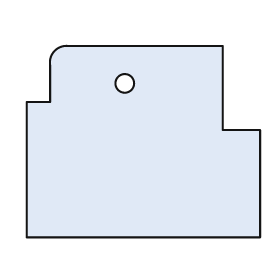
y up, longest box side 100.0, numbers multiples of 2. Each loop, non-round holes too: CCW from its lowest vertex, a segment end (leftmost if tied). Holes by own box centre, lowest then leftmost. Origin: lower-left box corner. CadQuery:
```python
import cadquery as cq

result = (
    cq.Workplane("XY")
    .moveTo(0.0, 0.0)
    .lineTo(100.0, 0.0)
    .lineTo(100.0, 46.0)
    .lineTo(84.0, 46.0)
    .lineTo(84.0, 82.0)
    .lineTo(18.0, 82.0)
    .threePointArc((12.0, 80.0), (10.0, 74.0))
    .lineTo(10.0, 58.0)
    .lineTo(0.0, 58.0)
    .close()
    .moveTo(42.0, 66.0)
    .circle(4.0)
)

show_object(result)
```